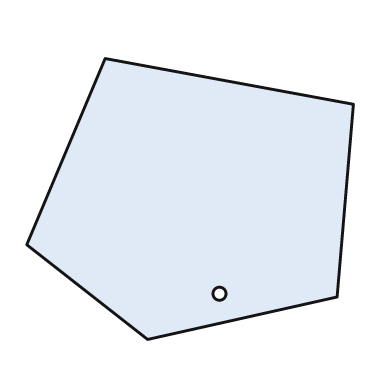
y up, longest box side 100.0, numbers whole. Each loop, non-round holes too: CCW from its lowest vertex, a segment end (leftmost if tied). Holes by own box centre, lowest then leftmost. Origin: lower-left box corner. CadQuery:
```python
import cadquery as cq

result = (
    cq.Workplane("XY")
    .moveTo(37.0, 0.0)
    .lineTo(95.0, 13.0)
    .lineTo(100.0, 72.0)
    .lineTo(24.0, 86.0)
    .lineTo(0.0, 29.0)
    .close()
    .moveTo(59.0, 14.0)
    .circle(2.0)
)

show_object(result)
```